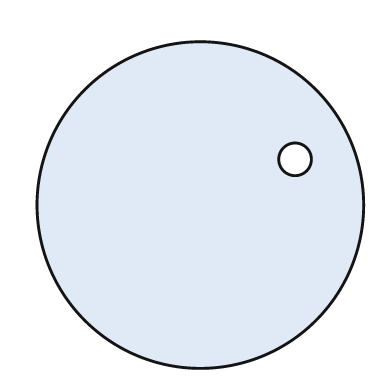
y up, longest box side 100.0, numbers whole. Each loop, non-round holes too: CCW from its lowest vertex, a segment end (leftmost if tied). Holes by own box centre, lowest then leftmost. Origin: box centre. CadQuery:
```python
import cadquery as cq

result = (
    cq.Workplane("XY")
    .moveTo(0.0, 0.0)
    .circle(50.0)
    .moveTo(29.0, 14.0)
    .circle(5.0)
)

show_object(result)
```